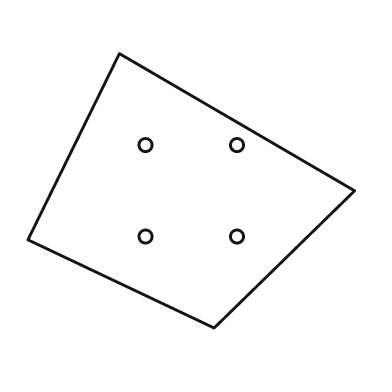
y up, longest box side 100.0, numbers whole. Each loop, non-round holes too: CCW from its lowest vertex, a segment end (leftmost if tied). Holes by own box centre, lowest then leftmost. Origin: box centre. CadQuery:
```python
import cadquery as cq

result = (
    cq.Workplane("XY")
    .moveTo(7.0, -42.0)
    .lineTo(50.0, 0.0)
    .lineTo(-22.0, 42.0)
    .lineTo(-50.0, -15.0)
    .close()
    .moveTo(-14.0, -14.0)
    .circle(2.0)
    .moveTo(14.0, -14.0)
    .circle(2.0)
    .moveTo(-14.0, 14.0)
    .circle(2.0)
    .moveTo(14.0, 14.0)
    .circle(2.0)
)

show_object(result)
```